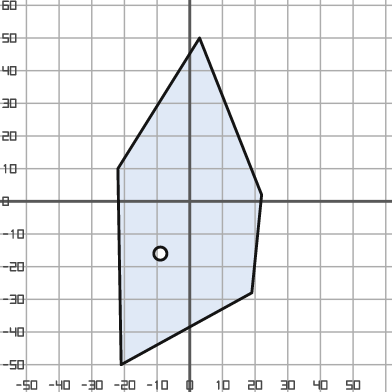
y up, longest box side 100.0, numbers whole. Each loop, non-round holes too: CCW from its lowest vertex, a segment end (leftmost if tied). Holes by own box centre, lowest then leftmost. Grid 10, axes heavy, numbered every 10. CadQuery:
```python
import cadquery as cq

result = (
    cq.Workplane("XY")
    .moveTo(-21.0, -50.0)
    .lineTo(19.0, -28.0)
    .lineTo(22.0, 2.0)
    .lineTo(3.0, 50.0)
    .lineTo(-22.0, 10.0)
    .close()
    .moveTo(-9.0, -16.0)
    .circle(2.0)
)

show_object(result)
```